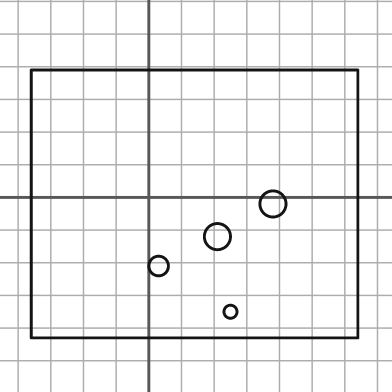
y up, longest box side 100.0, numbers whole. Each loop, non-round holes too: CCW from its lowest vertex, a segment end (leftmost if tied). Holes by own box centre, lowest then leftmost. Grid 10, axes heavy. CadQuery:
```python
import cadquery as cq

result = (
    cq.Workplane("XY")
    .moveTo(-36.0, -43.0)
    .lineTo(64.0, -43.0)
    .lineTo(64.0, 39.0)
    .lineTo(-36.0, 39.0)
    .close()
    .moveTo(25.0, -35.0)
    .circle(2.0)
    .moveTo(3.0, -21.0)
    .circle(3.0)
    .moveTo(21.0, -12.0)
    .circle(4.0)
    .moveTo(38.0, -2.0)
    .circle(4.0)
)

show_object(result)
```